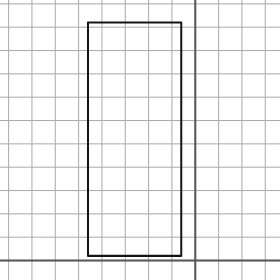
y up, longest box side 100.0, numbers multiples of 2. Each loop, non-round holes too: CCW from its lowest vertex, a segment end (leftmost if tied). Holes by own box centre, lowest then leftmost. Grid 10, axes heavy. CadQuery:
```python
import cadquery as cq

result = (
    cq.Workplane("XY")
    .moveTo(-46.0, 2.0)
    .lineTo(-6.0, 2.0)
    .lineTo(-6.0, 102.0)
    .lineTo(-46.0, 102.0)
    .close()
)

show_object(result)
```